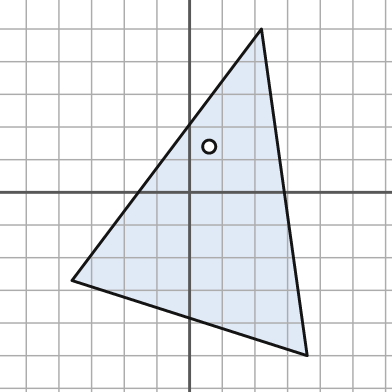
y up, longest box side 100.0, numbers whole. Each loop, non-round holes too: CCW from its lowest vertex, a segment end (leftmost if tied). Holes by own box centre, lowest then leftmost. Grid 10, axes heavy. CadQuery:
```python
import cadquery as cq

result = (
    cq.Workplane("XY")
    .moveTo(36.0, -50.0)
    .lineTo(22.0, 50.0)
    .lineTo(-36.0, -27.0)
    .close()
    .moveTo(6.0, 14.0)
    .circle(2.0)
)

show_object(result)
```